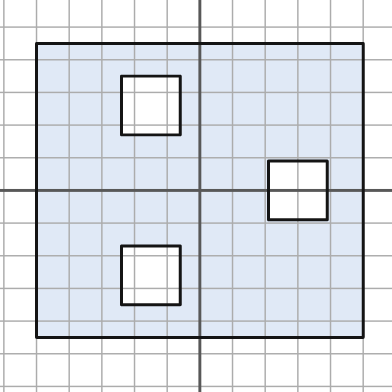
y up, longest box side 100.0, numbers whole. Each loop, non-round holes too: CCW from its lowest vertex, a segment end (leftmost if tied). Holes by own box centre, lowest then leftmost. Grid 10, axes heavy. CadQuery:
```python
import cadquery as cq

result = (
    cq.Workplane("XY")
    .moveTo(-50.0, -45.0)
    .lineTo(50.0, -45.0)
    .lineTo(50.0, 45.0)
    .lineTo(-50.0, 45.0)
    .close()
    .moveTo(-24.0, -35.0)
    .lineTo(-6.0, -35.0)
    .lineTo(-6.0, -17.0)
    .lineTo(-24.0, -17.0)
    .close()
    .moveTo(21.0, -9.0)
    .lineTo(39.0, -9.0)
    .lineTo(39.0, 9.0)
    .lineTo(21.0, 9.0)
    .close()
    .moveTo(-24.0, 17.0)
    .lineTo(-6.0, 17.0)
    .lineTo(-6.0, 35.0)
    .lineTo(-24.0, 35.0)
    .close()
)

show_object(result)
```